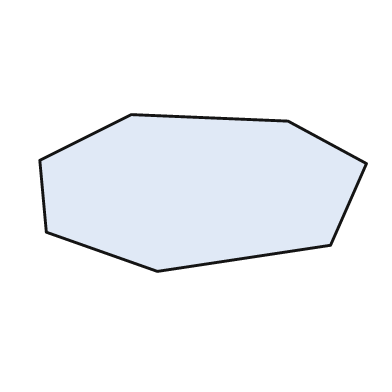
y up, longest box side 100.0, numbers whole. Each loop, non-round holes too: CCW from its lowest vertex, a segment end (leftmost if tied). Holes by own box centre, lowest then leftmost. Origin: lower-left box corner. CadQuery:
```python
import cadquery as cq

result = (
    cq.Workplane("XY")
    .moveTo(36.0, 0.0)
    .lineTo(89.0, 8.0)
    .lineTo(100.0, 33.0)
    .lineTo(76.0, 46.0)
    .lineTo(28.0, 48.0)
    .lineTo(0.0, 34.0)
    .lineTo(2.0, 12.0)
    .close()
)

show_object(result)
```